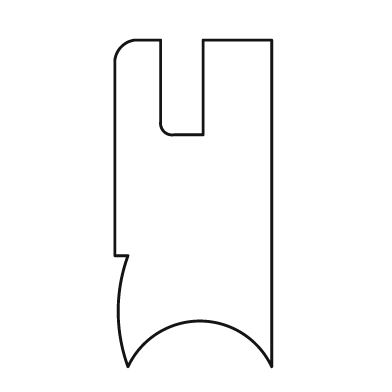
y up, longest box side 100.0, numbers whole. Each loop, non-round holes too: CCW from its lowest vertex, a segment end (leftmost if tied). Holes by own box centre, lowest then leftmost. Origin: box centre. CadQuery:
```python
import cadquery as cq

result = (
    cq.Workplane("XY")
    .moveTo(-20.0, -50.0)
    .threePointArc((2.0, -36.0), (24.0, -50.0))
    .lineTo(24.0, 50.0)
    .lineTo(3.0, 50.0)
    .lineTo(3.0, 21.0)
    .lineTo(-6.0, 21.0)
    .threePointArc((-9.0, 22.0), (-10.0, 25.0))
    .lineTo(-10.0, 50.0)
    .lineTo(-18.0, 50.0)
    .threePointArc((-22.0, 48.0), (-24.0, 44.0))
    .lineTo(-24.0, -16.0)
    .lineTo(-20.0, -16.0)
    .threePointArc((-23.0, -33.0), (-20.0, -50.0))
    .close()
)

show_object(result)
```